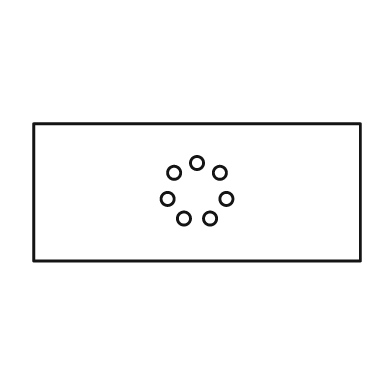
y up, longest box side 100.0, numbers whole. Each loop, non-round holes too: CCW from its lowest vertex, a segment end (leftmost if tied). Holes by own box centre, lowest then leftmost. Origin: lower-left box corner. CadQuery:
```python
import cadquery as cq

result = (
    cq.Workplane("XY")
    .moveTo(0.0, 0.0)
    .lineTo(100.0, 0.0)
    .lineTo(100.0, 42.0)
    .lineTo(0.0, 42.0)
    .close()
    .moveTo(46.0, 13.0)
    .circle(2.0)
    .moveTo(54.0, 13.0)
    .circle(2.0)
    .moveTo(41.0, 19.0)
    .circle(2.0)
    .moveTo(59.0, 19.0)
    .circle(2.0)
    .moveTo(43.0, 27.0)
    .circle(2.0)
    .moveTo(57.0, 27.0)
    .circle(2.0)
    .moveTo(50.0, 30.0)
    .circle(2.0)
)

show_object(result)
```